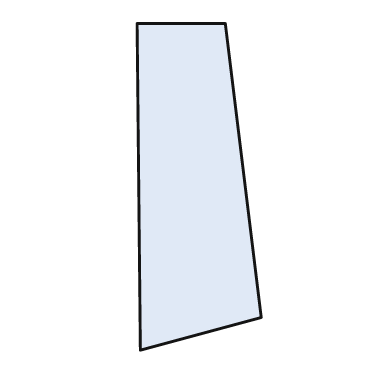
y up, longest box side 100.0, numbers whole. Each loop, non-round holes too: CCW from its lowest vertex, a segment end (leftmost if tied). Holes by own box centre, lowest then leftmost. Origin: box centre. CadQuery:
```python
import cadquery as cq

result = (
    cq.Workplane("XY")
    .moveTo(-18.0, -50.0)
    .lineTo(19.0, -40.0)
    .lineTo(8.0, 50.0)
    .lineTo(-19.0, 50.0)
    .close()
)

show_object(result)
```